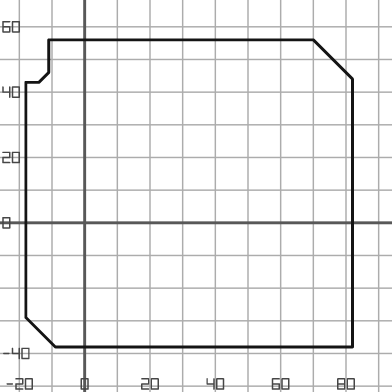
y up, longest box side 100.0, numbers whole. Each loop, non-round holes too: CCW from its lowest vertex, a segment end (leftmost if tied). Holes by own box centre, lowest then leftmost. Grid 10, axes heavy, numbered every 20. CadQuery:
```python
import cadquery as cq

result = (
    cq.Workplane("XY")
    .moveTo(-9.0, -38.0)
    .lineTo(82.0, -38.0)
    .lineTo(82.0, 44.0)
    .lineTo(70.0, 56.0)
    .lineTo(-11.0, 56.0)
    .lineTo(-11.0, 46.0)
    .lineTo(-14.0, 43.0)
    .lineTo(-18.0, 43.0)
    .lineTo(-18.0, -29.0)
    .close()
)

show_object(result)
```